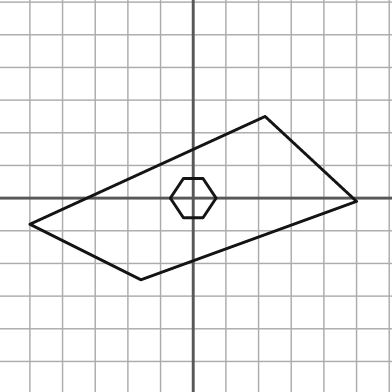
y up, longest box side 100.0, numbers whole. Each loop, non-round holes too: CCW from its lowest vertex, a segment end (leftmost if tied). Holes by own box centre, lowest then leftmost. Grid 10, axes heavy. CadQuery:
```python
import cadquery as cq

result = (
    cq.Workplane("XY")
    .moveTo(-16.0, -25.0)
    .lineTo(50.0, -1.0)
    .lineTo(22.0, 25.0)
    .lineTo(-50.0, -8.0)
    .close()
    .moveTo(-3.0, -6.0)
    .lineTo(3.0, -6.0)
    .lineTo(7.0, 0.0)
    .lineTo(3.0, 6.0)
    .lineTo(-3.0, 6.0)
    .lineTo(-7.0, 0.0)
    .close()
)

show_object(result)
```